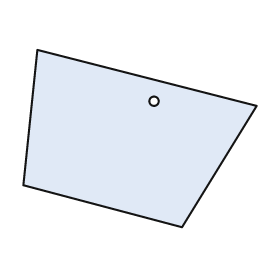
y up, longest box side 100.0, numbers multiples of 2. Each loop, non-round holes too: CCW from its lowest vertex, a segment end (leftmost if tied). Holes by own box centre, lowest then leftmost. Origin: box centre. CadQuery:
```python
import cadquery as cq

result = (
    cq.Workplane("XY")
    .moveTo(18.0, -38.0)
    .lineTo(50.0, 14.0)
    .lineTo(-44.0, 38.0)
    .lineTo(-50.0, -20.0)
    .close()
    .moveTo(6.0, 16.0)
    .circle(2.0)
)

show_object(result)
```